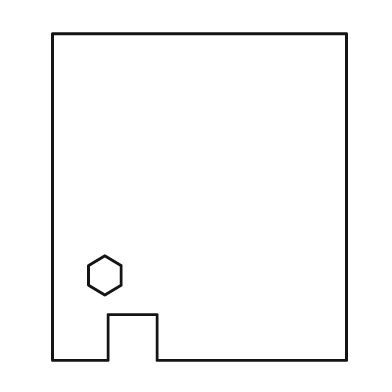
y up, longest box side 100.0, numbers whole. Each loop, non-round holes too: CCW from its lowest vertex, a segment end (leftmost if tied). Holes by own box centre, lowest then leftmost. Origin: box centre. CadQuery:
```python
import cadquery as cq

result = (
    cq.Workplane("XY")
    .moveTo(-45.0, -50.0)
    .lineTo(-28.0, -50.0)
    .lineTo(-28.0, -36.0)
    .lineTo(-13.0, -36.0)
    .lineTo(-13.0, -50.0)
    .lineTo(45.0, -50.0)
    .lineTo(45.0, 50.0)
    .lineTo(-45.0, 50.0)
    .close()
    .moveTo(-29.0, -30.0)
    .lineTo(-24.0, -27.0)
    .lineTo(-24.0, -21.0)
    .lineTo(-29.0, -18.0)
    .lineTo(-34.0, -21.0)
    .lineTo(-34.0, -27.0)
    .close()
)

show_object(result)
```